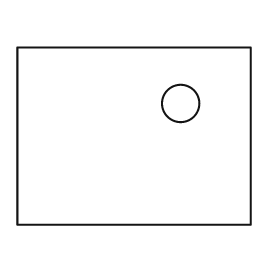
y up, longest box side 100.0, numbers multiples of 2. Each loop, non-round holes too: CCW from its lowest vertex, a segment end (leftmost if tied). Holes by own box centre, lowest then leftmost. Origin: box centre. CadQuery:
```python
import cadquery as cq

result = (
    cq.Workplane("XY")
    .moveTo(-50.0, -38.0)
    .lineTo(50.0, -38.0)
    .lineTo(50.0, 38.0)
    .lineTo(-50.0, 38.0)
    .close()
    .moveTo(20.0, 14.0)
    .circle(8.0)
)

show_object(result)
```